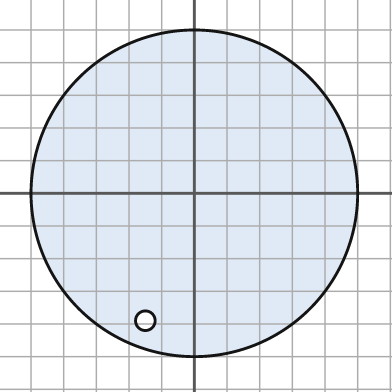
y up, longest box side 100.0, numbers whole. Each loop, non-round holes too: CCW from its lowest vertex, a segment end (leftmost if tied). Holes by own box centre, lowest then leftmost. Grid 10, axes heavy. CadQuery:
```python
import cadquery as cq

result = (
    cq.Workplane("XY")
    .moveTo(0.0, 0.0)
    .circle(50.0)
    .moveTo(-15.0, -39.0)
    .circle(3.0)
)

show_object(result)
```